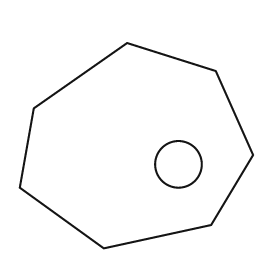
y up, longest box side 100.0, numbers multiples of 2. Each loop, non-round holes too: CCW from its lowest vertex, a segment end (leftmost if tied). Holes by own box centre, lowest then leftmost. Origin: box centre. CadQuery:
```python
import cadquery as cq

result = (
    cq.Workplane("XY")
    .moveTo(-14.0, -44.0)
    .lineTo(32.0, -34.0)
    .lineTo(50.0, -4.0)
    .lineTo(34.0, 32.0)
    .lineTo(-4.0, 44.0)
    .lineTo(-44.0, 16.0)
    .lineTo(-50.0, -18.0)
    .close()
    .moveTo(18.0, -8.0)
    .circle(10.0)
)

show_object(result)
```